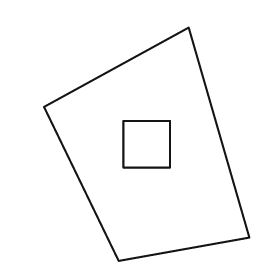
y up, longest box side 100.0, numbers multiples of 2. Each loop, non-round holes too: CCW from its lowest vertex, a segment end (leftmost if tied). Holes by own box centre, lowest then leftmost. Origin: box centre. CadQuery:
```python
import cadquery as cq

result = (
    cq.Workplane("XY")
    .moveTo(-12.0, -50.0)
    .lineTo(44.0, -40.0)
    .lineTo(18.0, 50.0)
    .lineTo(-44.0, 16.0)
    .close()
    .moveTo(-10.0, -10.0)
    .lineTo(10.0, -10.0)
    .lineTo(10.0, 10.0)
    .lineTo(-10.0, 10.0)
    .close()
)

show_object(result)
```